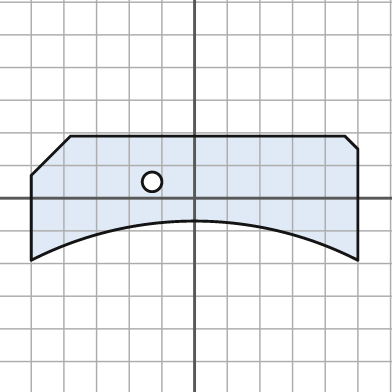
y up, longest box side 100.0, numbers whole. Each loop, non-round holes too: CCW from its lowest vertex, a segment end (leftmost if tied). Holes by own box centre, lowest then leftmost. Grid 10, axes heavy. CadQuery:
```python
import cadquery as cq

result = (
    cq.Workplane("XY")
    .moveTo(-50.0, -19.0)
    .threePointArc((0.0, -7.0), (50.0, -19.0))
    .lineTo(50.0, 15.0)
    .lineTo(46.0, 19.0)
    .lineTo(-38.0, 19.0)
    .lineTo(-50.0, 7.0)
    .close()
    .moveTo(-13.0, 5.0)
    .circle(3.0)
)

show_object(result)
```